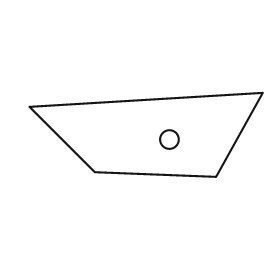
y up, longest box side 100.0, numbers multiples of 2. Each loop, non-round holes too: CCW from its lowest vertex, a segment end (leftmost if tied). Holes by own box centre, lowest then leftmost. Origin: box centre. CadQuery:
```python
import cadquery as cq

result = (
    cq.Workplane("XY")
    .moveTo(30.0, -18.0)
    .lineTo(50.0, 18.0)
    .lineTo(-50.0, 12.0)
    .lineTo(-22.0, -16.0)
    .close()
    .moveTo(10.0, -2.0)
    .circle(4.0)
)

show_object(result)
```